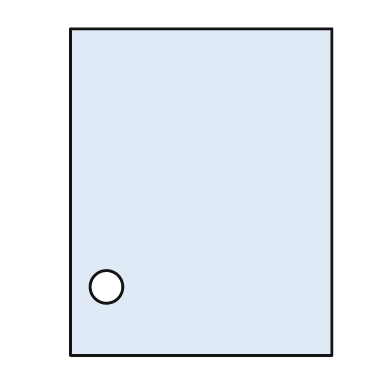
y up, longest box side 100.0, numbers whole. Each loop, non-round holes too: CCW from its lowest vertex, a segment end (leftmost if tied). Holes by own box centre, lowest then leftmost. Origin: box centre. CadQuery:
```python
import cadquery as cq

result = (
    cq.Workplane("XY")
    .moveTo(-40.0, -50.0)
    .lineTo(40.0, -50.0)
    .lineTo(40.0, 50.0)
    .lineTo(-40.0, 50.0)
    .close()
    .moveTo(-29.0, -29.0)
    .circle(5.0)
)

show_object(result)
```